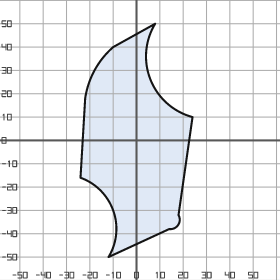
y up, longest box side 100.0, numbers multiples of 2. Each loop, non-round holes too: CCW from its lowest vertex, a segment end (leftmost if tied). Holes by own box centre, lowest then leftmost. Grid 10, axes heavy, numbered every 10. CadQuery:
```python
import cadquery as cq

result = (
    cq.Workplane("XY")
    .moveTo(-12.0, -50.0)
    .lineTo(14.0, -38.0)
    .threePointArc((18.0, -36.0), (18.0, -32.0))
    .lineTo(24.0, 10.0)
    .threePointArc((6.0, 26.0), (8.0, 50.0))
    .lineTo(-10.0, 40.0)
    .threePointArc((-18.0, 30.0), (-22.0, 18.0))
    .lineTo(-24.0, -16.0)
    .threePointArc((-10.0, -30.0), (-12.0, -50.0))
    .close()
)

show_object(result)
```